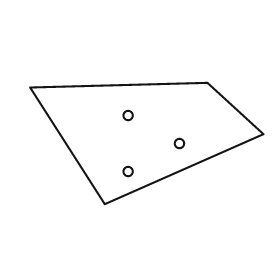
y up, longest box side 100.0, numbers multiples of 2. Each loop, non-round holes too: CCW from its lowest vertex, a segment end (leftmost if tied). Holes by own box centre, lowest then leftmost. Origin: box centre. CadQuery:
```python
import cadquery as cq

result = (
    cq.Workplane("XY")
    .moveTo(-18.0, -26.0)
    .lineTo(50.0, 4.0)
    .lineTo(26.0, 26.0)
    .lineTo(-50.0, 24.0)
    .close()
    .moveTo(-8.0, -12.0)
    .circle(2.0)
    .moveTo(14.0, 0.0)
    .circle(2.0)
    .moveTo(-8.0, 12.0)
    .circle(2.0)
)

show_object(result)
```